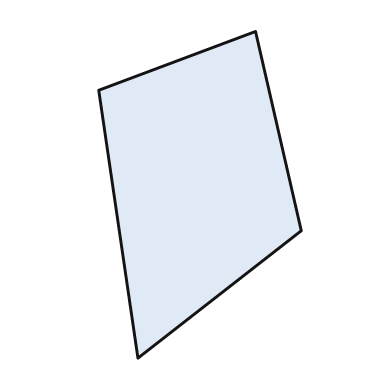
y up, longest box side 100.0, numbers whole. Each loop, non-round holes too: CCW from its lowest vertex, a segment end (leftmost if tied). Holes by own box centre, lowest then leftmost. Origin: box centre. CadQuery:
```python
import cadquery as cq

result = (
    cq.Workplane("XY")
    .moveTo(-19.0, -50.0)
    .lineTo(31.0, -11.0)
    .lineTo(17.0, 50.0)
    .lineTo(-31.0, 32.0)
    .close()
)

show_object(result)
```